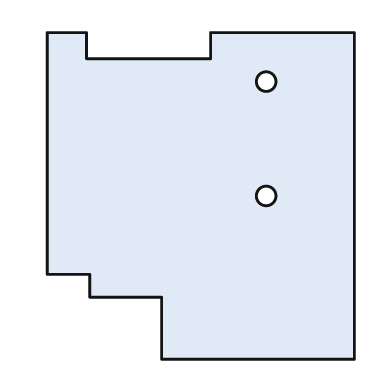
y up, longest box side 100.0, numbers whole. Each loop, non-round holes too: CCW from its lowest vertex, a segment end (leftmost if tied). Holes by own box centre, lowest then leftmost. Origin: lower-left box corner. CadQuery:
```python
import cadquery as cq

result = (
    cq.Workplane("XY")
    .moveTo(35.0, 0.0)
    .lineTo(94.0, 0.0)
    .lineTo(94.0, 100.0)
    .lineTo(50.0, 100.0)
    .lineTo(50.0, 92.0)
    .lineTo(12.0, 92.0)
    .lineTo(12.0, 100.0)
    .lineTo(0.0, 100.0)
    .lineTo(0.0, 26.0)
    .lineTo(13.0, 26.0)
    .lineTo(13.0, 19.0)
    .lineTo(35.0, 19.0)
    .close()
    .moveTo(67.0, 50.0)
    .circle(3.0)
    .moveTo(67.0, 85.0)
    .circle(3.0)
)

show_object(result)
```